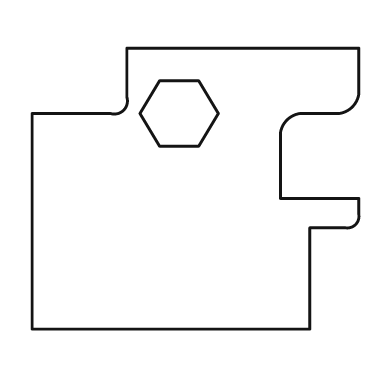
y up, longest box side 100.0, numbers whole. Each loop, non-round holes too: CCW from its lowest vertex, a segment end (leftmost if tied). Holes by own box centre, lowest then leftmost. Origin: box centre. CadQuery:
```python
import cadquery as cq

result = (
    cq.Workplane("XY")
    .moveTo(-50.0, -43.0)
    .lineTo(35.0, -43.0)
    .lineTo(35.0, -12.0)
    .lineTo(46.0, -12.0)
    .threePointArc((49.0, -11.0), (50.0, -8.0))
    .lineTo(50.0, -3.0)
    .lineTo(26.0, -3.0)
    .lineTo(26.0, 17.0)
    .threePointArc((28.0, 21.0), (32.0, 23.0))
    .lineTo(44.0, 23.0)
    .threePointArc((48.0, 25.0), (50.0, 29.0))
    .lineTo(50.0, 43.0)
    .lineTo(-21.0, 43.0)
    .lineTo(-21.0, 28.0)
    .threePointArc((-22.0, 24.0), (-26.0, 23.0))
    .lineTo(-50.0, 23.0)
    .close()
    .moveTo(-11.0, 13.0)
    .lineTo(1.0, 13.0)
    .lineTo(7.0, 23.0)
    .lineTo(1.0, 33.0)
    .lineTo(-11.0, 33.0)
    .lineTo(-17.0, 23.0)
    .close()
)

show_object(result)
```